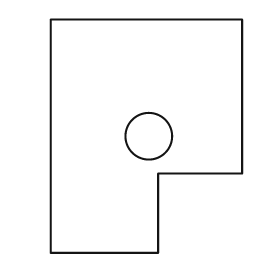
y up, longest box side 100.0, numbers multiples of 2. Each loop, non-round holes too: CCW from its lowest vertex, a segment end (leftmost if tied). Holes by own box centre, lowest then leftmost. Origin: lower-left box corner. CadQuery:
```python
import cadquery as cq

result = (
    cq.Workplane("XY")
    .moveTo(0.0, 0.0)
    .lineTo(46.0, 0.0)
    .lineTo(46.0, 34.0)
    .lineTo(82.0, 34.0)
    .lineTo(82.0, 100.0)
    .lineTo(0.0, 100.0)
    .close()
    .moveTo(42.0, 50.0)
    .circle(10.0)
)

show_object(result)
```